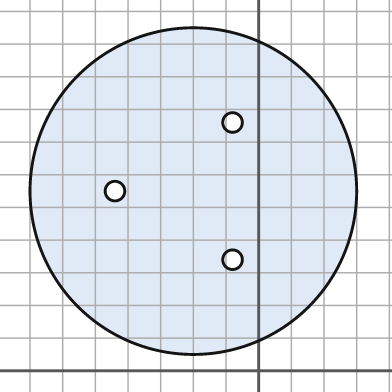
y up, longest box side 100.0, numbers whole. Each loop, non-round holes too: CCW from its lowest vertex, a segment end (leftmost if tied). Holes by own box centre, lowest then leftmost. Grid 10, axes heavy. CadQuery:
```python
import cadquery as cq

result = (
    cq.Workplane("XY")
    .moveTo(-20.0, 55.0)
    .circle(50.0)
    .moveTo(-8.0, 34.0)
    .circle(3.0)
    .moveTo(-44.0, 55.0)
    .circle(3.0)
    .moveTo(-8.0, 76.0)
    .circle(3.0)
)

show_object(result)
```